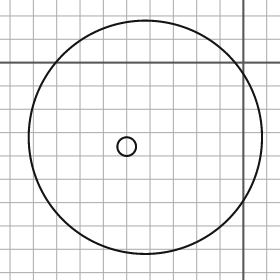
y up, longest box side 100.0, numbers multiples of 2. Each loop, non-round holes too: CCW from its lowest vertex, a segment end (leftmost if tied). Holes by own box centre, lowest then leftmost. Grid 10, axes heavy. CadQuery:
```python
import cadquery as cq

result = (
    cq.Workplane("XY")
    .moveTo(-42.0, -32.0)
    .circle(50.0)
    .moveTo(-50.0, -36.0)
    .circle(4.0)
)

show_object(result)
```